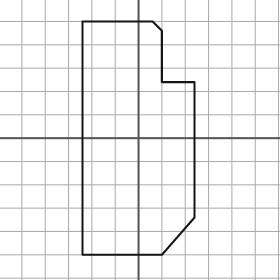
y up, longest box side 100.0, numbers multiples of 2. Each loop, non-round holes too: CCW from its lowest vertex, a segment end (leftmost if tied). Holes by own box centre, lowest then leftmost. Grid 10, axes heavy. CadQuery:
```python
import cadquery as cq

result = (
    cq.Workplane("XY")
    .moveTo(-24.0, -50.0)
    .lineTo(10.0, -50.0)
    .lineTo(24.0, -34.0)
    .lineTo(24.0, 24.0)
    .lineTo(10.0, 24.0)
    .lineTo(10.0, 46.0)
    .lineTo(6.0, 50.0)
    .lineTo(-24.0, 50.0)
    .close()
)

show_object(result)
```